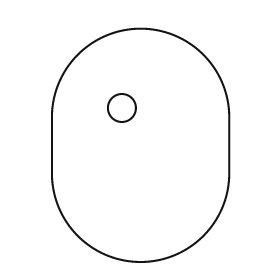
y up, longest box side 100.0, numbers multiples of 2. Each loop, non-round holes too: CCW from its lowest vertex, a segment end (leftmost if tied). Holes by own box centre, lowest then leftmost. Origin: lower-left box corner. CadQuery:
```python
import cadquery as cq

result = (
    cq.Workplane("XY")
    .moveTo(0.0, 38.0)
    .threePointArc((38.0, 0.0), (76.0, 38.0))
    .lineTo(76.0, 62.0)
    .threePointArc((38.0, 100.0), (0.0, 62.0))
    .close()
    .moveTo(30.0, 66.0)
    .circle(6.0)
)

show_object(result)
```